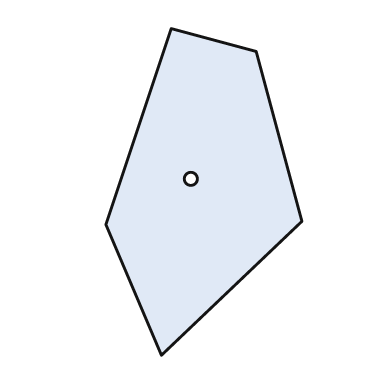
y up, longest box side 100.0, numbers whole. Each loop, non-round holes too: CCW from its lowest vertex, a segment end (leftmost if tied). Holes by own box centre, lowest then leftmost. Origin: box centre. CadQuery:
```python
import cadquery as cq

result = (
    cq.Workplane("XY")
    .moveTo(-13.0, -50.0)
    .lineTo(30.0, -9.0)
    .lineTo(16.0, 43.0)
    .lineTo(-10.0, 50.0)
    .lineTo(-30.0, -10.0)
    .close()
    .moveTo(-4.0, 4.0)
    .circle(2.0)
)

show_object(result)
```